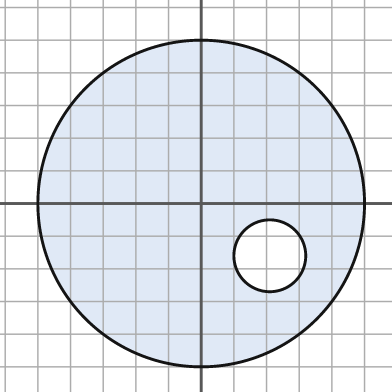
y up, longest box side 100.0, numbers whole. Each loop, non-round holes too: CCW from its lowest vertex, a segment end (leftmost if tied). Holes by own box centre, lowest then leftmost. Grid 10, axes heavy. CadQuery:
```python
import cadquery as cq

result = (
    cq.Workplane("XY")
    .moveTo(0.0, 0.0)
    .circle(50.0)
    .moveTo(21.0, -16.0)
    .circle(11.0)
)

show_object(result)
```